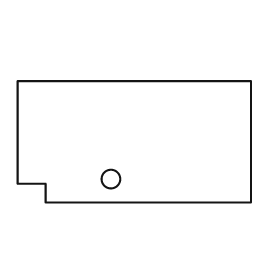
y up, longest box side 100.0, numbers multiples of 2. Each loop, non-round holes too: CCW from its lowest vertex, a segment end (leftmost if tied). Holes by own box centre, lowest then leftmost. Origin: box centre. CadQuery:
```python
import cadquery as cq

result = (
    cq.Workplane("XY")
    .moveTo(-38.0, -26.0)
    .lineTo(50.0, -26.0)
    .lineTo(50.0, 26.0)
    .lineTo(-50.0, 26.0)
    .lineTo(-50.0, -18.0)
    .lineTo(-38.0, -18.0)
    .close()
    .moveTo(-10.0, -16.0)
    .circle(4.0)
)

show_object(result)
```